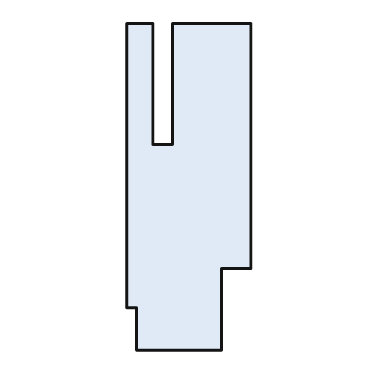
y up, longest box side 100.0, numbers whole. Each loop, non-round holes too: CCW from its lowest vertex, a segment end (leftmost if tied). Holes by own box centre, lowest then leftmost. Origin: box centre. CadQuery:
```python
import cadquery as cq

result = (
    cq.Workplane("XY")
    .moveTo(-16.0, -50.0)
    .lineTo(10.0, -50.0)
    .lineTo(10.0, -25.0)
    .lineTo(19.0, -25.0)
    .lineTo(19.0, 50.0)
    .lineTo(-5.0, 50.0)
    .lineTo(-5.0, 13.0)
    .lineTo(-11.0, 13.0)
    .lineTo(-11.0, 50.0)
    .lineTo(-19.0, 50.0)
    .lineTo(-19.0, -37.0)
    .lineTo(-16.0, -37.0)
    .close()
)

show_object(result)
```